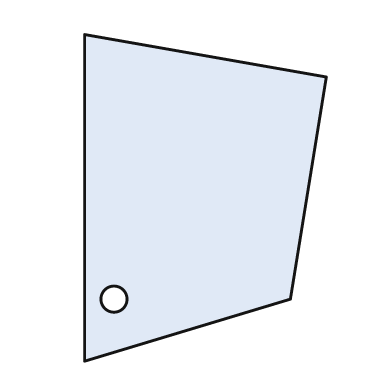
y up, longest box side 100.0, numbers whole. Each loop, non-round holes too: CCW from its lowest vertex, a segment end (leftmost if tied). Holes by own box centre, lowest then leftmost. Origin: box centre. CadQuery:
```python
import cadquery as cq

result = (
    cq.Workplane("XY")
    .moveTo(-37.0, -50.0)
    .lineTo(26.0, -31.0)
    .lineTo(37.0, 37.0)
    .lineTo(-37.0, 50.0)
    .close()
    .moveTo(-28.0, -31.0)
    .circle(4.0)
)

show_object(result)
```